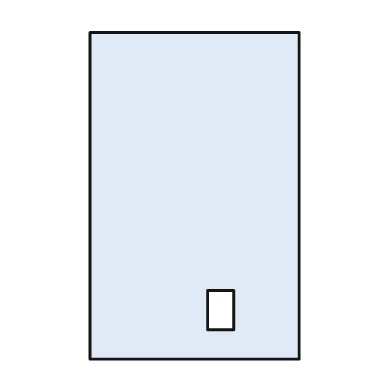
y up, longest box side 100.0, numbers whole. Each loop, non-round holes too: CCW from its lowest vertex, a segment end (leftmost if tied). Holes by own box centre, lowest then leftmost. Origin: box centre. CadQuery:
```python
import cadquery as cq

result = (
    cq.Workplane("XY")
    .moveTo(-32.0, -50.0)
    .lineTo(32.0, -50.0)
    .lineTo(32.0, 50.0)
    .lineTo(-32.0, 50.0)
    .close()
    .moveTo(4.0, -41.0)
    .lineTo(12.0, -41.0)
    .lineTo(12.0, -29.0)
    .lineTo(4.0, -29.0)
    .close()
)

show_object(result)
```